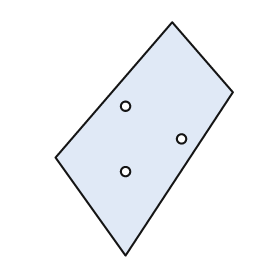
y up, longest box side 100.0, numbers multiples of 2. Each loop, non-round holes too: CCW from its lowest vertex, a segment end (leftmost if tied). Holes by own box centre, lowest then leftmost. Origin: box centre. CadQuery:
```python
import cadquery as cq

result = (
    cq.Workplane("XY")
    .moveTo(-8.0, -50.0)
    .lineTo(38.0, 20.0)
    .lineTo(12.0, 50.0)
    .lineTo(-38.0, -8.0)
    .close()
    .moveTo(-8.0, -14.0)
    .circle(2.0)
    .moveTo(16.0, 0.0)
    .circle(2.0)
    .moveTo(-8.0, 14.0)
    .circle(2.0)
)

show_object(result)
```